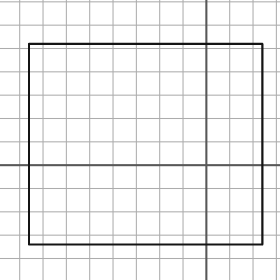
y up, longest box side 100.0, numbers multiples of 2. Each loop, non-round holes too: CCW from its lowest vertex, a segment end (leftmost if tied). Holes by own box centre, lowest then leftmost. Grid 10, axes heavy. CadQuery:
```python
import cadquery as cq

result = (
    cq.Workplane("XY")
    .moveTo(-76.0, -34.0)
    .lineTo(24.0, -34.0)
    .lineTo(24.0, 52.0)
    .lineTo(-76.0, 52.0)
    .close()
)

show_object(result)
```